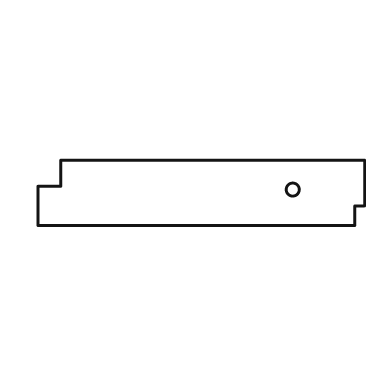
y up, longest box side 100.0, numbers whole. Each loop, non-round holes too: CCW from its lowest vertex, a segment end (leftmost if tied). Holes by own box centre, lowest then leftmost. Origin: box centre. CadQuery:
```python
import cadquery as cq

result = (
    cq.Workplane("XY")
    .moveTo(-50.0, -10.0)
    .lineTo(47.0, -10.0)
    .lineTo(47.0, -4.0)
    .lineTo(50.0, -4.0)
    .lineTo(50.0, 10.0)
    .lineTo(-43.0, 10.0)
    .lineTo(-43.0, 2.0)
    .lineTo(-50.0, 2.0)
    .close()
    .moveTo(28.0, 1.0)
    .circle(2.0)
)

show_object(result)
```